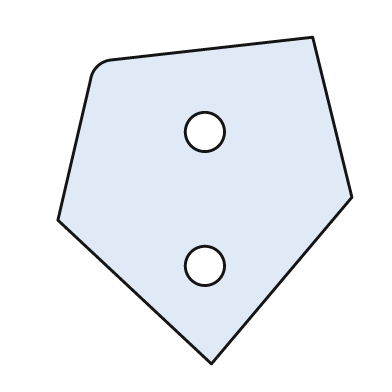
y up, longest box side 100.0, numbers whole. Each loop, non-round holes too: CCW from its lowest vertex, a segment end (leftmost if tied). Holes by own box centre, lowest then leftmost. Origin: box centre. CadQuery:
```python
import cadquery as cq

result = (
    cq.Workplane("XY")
    .moveTo(2.0, -50.0)
    .lineTo(45.0, 1.0)
    .lineTo(33.0, 50.0)
    .lineTo(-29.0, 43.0)
    .threePointArc((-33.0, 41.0), (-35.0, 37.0))
    .lineTo(-45.0, -6.0)
    .close()
    .moveTo(0.0, -20.0)
    .circle(6.0)
    .moveTo(0.0, 21.0)
    .circle(6.0)
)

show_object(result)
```